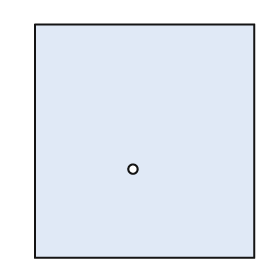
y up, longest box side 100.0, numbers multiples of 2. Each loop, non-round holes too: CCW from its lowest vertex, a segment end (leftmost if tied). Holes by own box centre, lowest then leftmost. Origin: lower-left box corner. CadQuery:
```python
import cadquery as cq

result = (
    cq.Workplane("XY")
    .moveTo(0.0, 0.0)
    .lineTo(94.0, 0.0)
    .lineTo(94.0, 100.0)
    .lineTo(0.0, 100.0)
    .close()
    .moveTo(42.0, 38.0)
    .circle(2.0)
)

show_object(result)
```